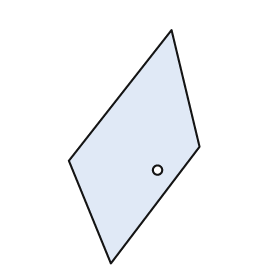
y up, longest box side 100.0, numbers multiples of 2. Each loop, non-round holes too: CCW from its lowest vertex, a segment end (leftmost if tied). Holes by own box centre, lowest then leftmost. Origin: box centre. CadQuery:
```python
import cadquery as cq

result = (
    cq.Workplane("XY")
    .moveTo(-10.0, -50.0)
    .lineTo(28.0, 0.0)
    .lineTo(16.0, 50.0)
    .lineTo(-28.0, -6.0)
    .close()
    .moveTo(10.0, -10.0)
    .circle(2.0)
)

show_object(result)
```